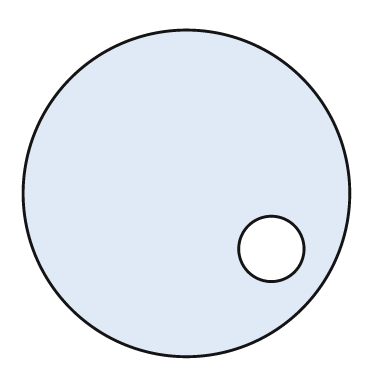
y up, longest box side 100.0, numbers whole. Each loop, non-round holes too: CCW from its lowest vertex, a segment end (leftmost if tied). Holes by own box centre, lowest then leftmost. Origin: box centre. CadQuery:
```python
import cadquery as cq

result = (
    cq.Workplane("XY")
    .moveTo(0.0, 0.0)
    .circle(50.0)
    .moveTo(26.0, -17.0)
    .circle(10.0)
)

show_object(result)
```